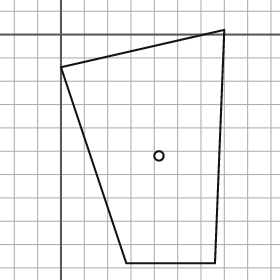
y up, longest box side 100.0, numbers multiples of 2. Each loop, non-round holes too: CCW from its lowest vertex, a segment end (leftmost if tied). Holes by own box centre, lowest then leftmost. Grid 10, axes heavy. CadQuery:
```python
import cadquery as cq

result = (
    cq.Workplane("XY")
    .moveTo(28.0, -98.0)
    .lineTo(66.0, -98.0)
    .lineTo(70.0, 2.0)
    .lineTo(0.0, -14.0)
    .close()
    .moveTo(42.0, -52.0)
    .circle(2.0)
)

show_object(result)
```